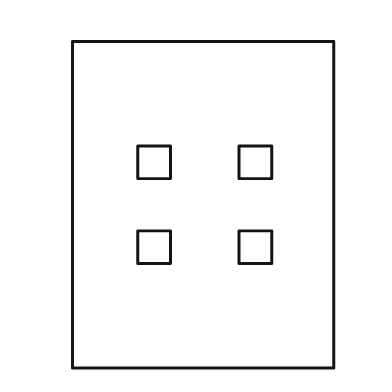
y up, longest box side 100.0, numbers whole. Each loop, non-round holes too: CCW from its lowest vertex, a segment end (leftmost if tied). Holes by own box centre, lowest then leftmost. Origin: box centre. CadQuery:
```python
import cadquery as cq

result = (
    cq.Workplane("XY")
    .moveTo(-40.0, -50.0)
    .lineTo(40.0, -50.0)
    .lineTo(40.0, 50.0)
    .lineTo(-40.0, 50.0)
    .close()
    .moveTo(-20.0, -18.0)
    .lineTo(-10.0, -18.0)
    .lineTo(-10.0, -8.0)
    .lineTo(-20.0, -8.0)
    .close()
    .moveTo(11.0, -18.0)
    .lineTo(21.0, -18.0)
    .lineTo(21.0, -8.0)
    .lineTo(11.0, -8.0)
    .close()
    .moveTo(-20.0, 8.0)
    .lineTo(-10.0, 8.0)
    .lineTo(-10.0, 18.0)
    .lineTo(-20.0, 18.0)
    .close()
    .moveTo(11.0, 8.0)
    .lineTo(21.0, 8.0)
    .lineTo(21.0, 18.0)
    .lineTo(11.0, 18.0)
    .close()
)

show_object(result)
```